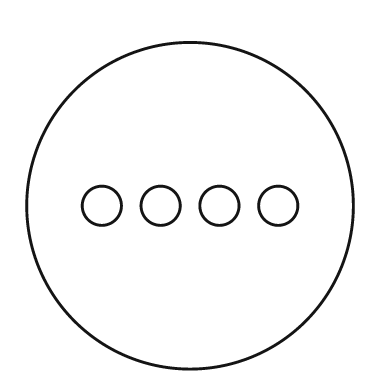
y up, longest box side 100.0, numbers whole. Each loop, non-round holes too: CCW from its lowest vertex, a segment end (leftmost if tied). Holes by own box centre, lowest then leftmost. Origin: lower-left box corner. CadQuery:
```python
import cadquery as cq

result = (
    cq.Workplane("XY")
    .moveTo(50.0, 50.0)
    .circle(50.0)
    .moveTo(23.0, 50.0)
    .circle(6.0)
    .moveTo(41.0, 50.0)
    .circle(6.0)
    .moveTo(59.0, 50.0)
    .circle(6.0)
    .moveTo(77.0, 50.0)
    .circle(6.0)
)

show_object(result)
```